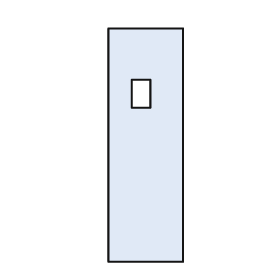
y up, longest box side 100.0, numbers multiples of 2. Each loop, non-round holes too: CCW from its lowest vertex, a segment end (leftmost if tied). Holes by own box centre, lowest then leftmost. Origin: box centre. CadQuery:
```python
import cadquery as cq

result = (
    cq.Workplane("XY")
    .moveTo(-16.0, -50.0)
    .lineTo(16.0, -50.0)
    .lineTo(16.0, 50.0)
    .lineTo(-16.0, 50.0)
    .close()
    .moveTo(-6.0, 16.0)
    .lineTo(2.0, 16.0)
    .lineTo(2.0, 28.0)
    .lineTo(-6.0, 28.0)
    .close()
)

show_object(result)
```